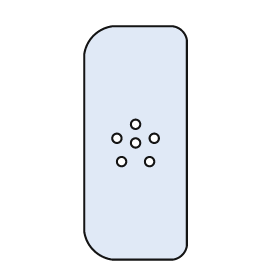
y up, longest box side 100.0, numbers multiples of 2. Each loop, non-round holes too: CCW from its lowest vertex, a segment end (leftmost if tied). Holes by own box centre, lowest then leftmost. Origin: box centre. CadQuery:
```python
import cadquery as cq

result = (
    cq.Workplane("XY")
    .moveTo(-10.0, -50.0)
    .lineTo(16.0, -50.0)
    .threePointArc((20.0, -48.0), (22.0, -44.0))
    .lineTo(22.0, 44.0)
    .threePointArc((20.0, 48.0), (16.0, 50.0))
    .lineTo(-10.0, 50.0)
    .threePointArc((-18.0, 46.0), (-22.0, 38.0))
    .lineTo(-22.0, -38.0)
    .threePointArc((-18.0, -46.0), (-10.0, -50.0))
    .close()
    .moveTo(-6.0, -8.0)
    .circle(2.0)
    .moveTo(6.0, -8.0)
    .circle(2.0)
    .moveTo(0.0, 0.0)
    .circle(2.0)
    .moveTo(-8.0, 2.0)
    .circle(2.0)
    .moveTo(8.0, 2.0)
    .circle(2.0)
    .moveTo(0.0, 8.0)
    .circle(2.0)
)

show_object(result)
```